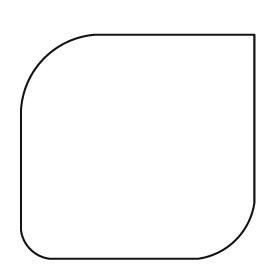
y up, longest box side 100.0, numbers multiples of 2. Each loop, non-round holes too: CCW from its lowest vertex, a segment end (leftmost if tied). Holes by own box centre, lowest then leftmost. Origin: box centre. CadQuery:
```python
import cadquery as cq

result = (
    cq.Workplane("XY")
    .moveTo(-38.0, -48.0)
    .lineTo(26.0, -48.0)
    .threePointArc((42.0, -40.0), (50.0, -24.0))
    .lineTo(50.0, 48.0)
    .lineTo(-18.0, 48.0)
    .threePointArc((-40.0, 38.0), (-50.0, 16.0))
    .lineTo(-50.0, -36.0)
    .threePointArc((-46.0, -44.0), (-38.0, -48.0))
    .close()
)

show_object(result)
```